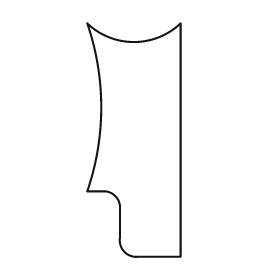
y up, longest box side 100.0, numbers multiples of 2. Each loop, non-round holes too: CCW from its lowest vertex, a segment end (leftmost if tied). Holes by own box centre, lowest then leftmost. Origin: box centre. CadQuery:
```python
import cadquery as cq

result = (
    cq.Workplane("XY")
    .moveTo(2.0, -50.0)
    .lineTo(20.0, -50.0)
    .lineTo(20.0, 50.0)
    .threePointArc((0.0, 42.0), (-20.0, 50.0))
    .threePointArc((-14.0, 14.0), (-20.0, -22.0))
    .lineTo(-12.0, -22.0)
    .threePointArc((-8.0, -24.0), (-6.0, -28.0))
    .lineTo(-6.0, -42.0)
    .threePointArc((-4.0, -48.0), (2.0, -50.0))
    .close()
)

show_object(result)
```